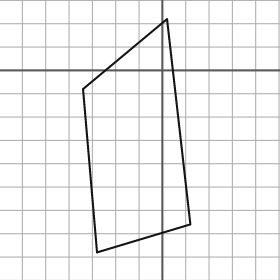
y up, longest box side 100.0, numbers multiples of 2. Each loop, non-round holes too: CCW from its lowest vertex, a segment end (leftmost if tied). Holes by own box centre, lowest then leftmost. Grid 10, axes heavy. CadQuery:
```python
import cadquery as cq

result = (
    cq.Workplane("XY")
    .moveTo(-28.0, -78.0)
    .lineTo(12.0, -66.0)
    .lineTo(2.0, 22.0)
    .lineTo(-34.0, -8.0)
    .close()
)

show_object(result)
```